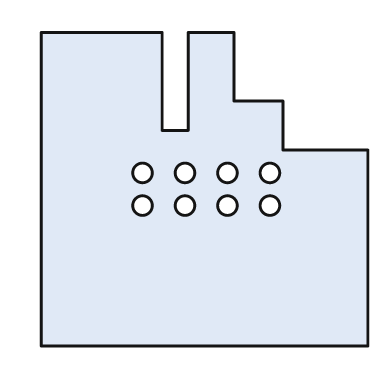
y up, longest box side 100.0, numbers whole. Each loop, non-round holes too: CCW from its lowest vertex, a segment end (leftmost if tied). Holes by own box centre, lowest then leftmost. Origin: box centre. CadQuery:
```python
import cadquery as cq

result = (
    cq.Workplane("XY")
    .moveTo(-50.0, -48.0)
    .lineTo(50.0, -48.0)
    .lineTo(50.0, 12.0)
    .lineTo(24.0, 12.0)
    .lineTo(24.0, 27.0)
    .lineTo(9.0, 27.0)
    .lineTo(9.0, 48.0)
    .lineTo(-5.0, 48.0)
    .lineTo(-5.0, 18.0)
    .lineTo(-13.0, 18.0)
    .lineTo(-13.0, 48.0)
    .lineTo(-50.0, 48.0)
    .close()
    .moveTo(-19.0, -5.0)
    .circle(3.0)
    .moveTo(-6.0, -5.0)
    .circle(3.0)
    .moveTo(7.0, -5.0)
    .circle(3.0)
    .moveTo(20.0, -5.0)
    .circle(3.0)
    .moveTo(-19.0, 5.0)
    .circle(3.0)
    .moveTo(-6.0, 5.0)
    .circle(3.0)
    .moveTo(7.0, 5.0)
    .circle(3.0)
    .moveTo(20.0, 5.0)
    .circle(3.0)
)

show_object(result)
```